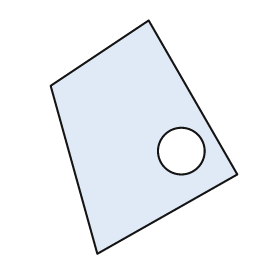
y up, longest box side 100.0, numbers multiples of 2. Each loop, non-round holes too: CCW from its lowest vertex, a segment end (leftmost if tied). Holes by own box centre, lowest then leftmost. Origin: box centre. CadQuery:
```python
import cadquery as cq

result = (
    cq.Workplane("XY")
    .moveTo(-20.0, -50.0)
    .lineTo(40.0, -16.0)
    .lineTo(2.0, 50.0)
    .lineTo(-40.0, 22.0)
    .close()
    .moveTo(16.0, -6.0)
    .circle(10.0)
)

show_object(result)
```